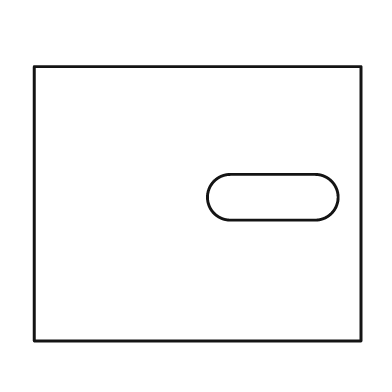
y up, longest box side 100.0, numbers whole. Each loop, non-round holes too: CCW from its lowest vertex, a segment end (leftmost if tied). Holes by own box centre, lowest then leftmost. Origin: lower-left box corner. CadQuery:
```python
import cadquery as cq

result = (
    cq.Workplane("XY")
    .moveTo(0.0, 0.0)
    .lineTo(100.0, 0.0)
    .lineTo(100.0, 84.0)
    .lineTo(0.0, 84.0)
    .close()
    .moveTo(60.0, 37.0)
    .lineTo(86.0, 37.0)
    .threePointArc((93.0, 44.0), (86.0, 51.0))
    .lineTo(60.0, 51.0)
    .threePointArc((53.0, 44.0), (60.0, 37.0))
    .close()
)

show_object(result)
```